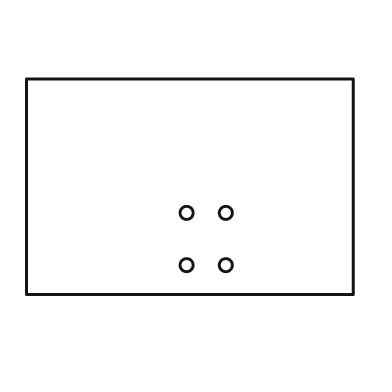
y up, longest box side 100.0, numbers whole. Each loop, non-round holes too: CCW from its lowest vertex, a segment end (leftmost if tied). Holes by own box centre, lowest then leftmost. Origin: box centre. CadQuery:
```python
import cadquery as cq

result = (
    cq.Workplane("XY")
    .moveTo(-50.0, -33.0)
    .lineTo(50.0, -33.0)
    .lineTo(50.0, 33.0)
    .lineTo(-50.0, 33.0)
    .close()
    .moveTo(-1.0, -24.0)
    .circle(2.0)
    .moveTo(11.0, -24.0)
    .circle(2.0)
    .moveTo(-1.0, -8.0)
    .circle(2.0)
    .moveTo(11.0, -8.0)
    .circle(2.0)
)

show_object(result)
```